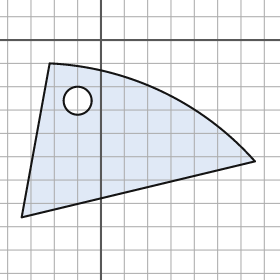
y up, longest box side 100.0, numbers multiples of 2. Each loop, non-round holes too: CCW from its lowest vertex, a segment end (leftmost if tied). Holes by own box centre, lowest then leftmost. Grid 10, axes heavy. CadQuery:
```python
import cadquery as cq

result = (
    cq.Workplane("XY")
    .moveTo(-34.0, -76.0)
    .lineTo(66.0, -52.0)
    .threePointArc((26.0, -22.0), (-22.0, -10.0))
    .close()
    .moveTo(-10.0, -26.0)
    .circle(6.0)
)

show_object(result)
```